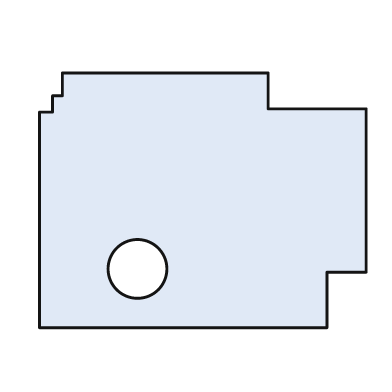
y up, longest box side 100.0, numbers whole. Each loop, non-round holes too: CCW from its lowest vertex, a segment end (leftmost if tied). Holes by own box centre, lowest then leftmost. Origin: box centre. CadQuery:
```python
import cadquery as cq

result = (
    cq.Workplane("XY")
    .moveTo(-50.0, -39.0)
    .lineTo(38.0, -39.0)
    .lineTo(38.0, -22.0)
    .lineTo(50.0, -22.0)
    .lineTo(50.0, 28.0)
    .lineTo(20.0, 28.0)
    .lineTo(20.0, 39.0)
    .lineTo(-43.0, 39.0)
    .lineTo(-43.0, 32.0)
    .lineTo(-46.0, 32.0)
    .lineTo(-46.0, 27.0)
    .lineTo(-50.0, 27.0)
    .close()
    .moveTo(-20.0, -21.0)
    .circle(9.0)
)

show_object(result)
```